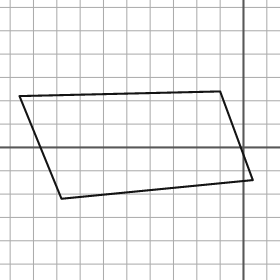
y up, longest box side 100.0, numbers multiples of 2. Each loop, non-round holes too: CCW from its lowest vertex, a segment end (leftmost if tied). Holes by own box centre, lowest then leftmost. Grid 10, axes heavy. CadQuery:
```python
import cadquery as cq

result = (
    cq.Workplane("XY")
    .moveTo(-78.0, -22.0)
    .lineTo(4.0, -14.0)
    .lineTo(-10.0, 24.0)
    .lineTo(-96.0, 22.0)
    .close()
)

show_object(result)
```